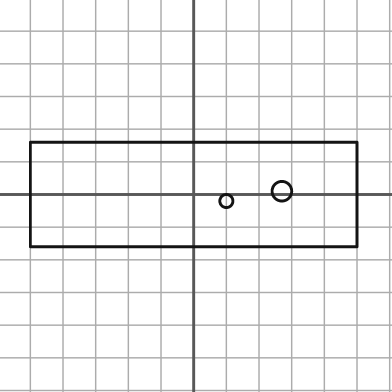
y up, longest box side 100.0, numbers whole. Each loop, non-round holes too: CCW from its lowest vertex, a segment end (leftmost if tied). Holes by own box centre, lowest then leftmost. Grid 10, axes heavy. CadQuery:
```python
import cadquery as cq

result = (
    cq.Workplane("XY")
    .moveTo(-50.0, -16.0)
    .lineTo(50.0, -16.0)
    .lineTo(50.0, 16.0)
    .lineTo(-50.0, 16.0)
    .close()
    .moveTo(10.0, -2.0)
    .circle(2.0)
    .moveTo(27.0, 1.0)
    .circle(3.0)
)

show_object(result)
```